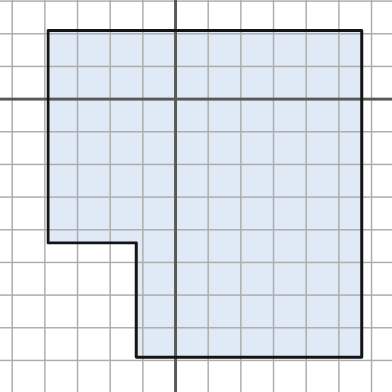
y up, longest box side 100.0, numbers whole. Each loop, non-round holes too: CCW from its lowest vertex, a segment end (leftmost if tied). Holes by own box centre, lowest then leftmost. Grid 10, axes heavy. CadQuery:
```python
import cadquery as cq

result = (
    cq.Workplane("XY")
    .moveTo(-12.0, -79.0)
    .lineTo(57.0, -79.0)
    .lineTo(57.0, 21.0)
    .lineTo(-39.0, 21.0)
    .lineTo(-39.0, -44.0)
    .lineTo(-12.0, -44.0)
    .close()
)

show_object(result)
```